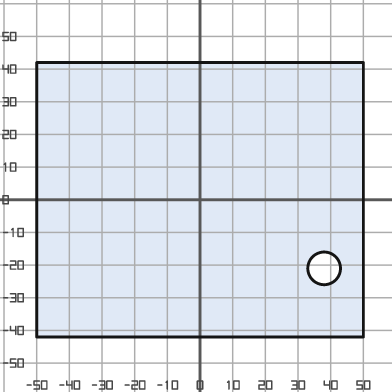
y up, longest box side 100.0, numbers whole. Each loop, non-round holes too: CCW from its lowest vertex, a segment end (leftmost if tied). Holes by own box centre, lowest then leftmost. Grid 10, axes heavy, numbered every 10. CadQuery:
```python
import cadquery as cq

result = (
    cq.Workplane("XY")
    .moveTo(-50.0, -42.0)
    .lineTo(50.0, -42.0)
    .lineTo(50.0, 42.0)
    .lineTo(-50.0, 42.0)
    .close()
    .moveTo(38.0, -21.0)
    .circle(5.0)
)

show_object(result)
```